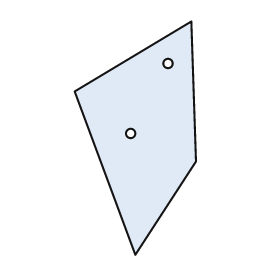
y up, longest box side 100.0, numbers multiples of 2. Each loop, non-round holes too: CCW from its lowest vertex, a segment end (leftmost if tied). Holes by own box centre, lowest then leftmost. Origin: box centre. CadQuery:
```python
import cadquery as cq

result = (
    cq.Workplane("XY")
    .moveTo(0.0, -50.0)
    .lineTo(26.0, -10.0)
    .lineTo(24.0, 50.0)
    .lineTo(-26.0, 20.0)
    .close()
    .moveTo(-2.0, 2.0)
    .circle(2.0)
    .moveTo(14.0, 32.0)
    .circle(2.0)
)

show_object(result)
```